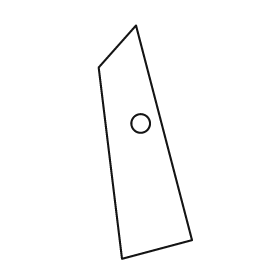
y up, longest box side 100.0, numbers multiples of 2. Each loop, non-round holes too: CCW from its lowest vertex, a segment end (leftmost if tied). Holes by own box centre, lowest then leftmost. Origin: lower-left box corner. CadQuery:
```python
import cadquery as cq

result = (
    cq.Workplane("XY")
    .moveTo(10.0, 0.0)
    .lineTo(40.0, 8.0)
    .lineTo(16.0, 100.0)
    .lineTo(0.0, 82.0)
    .close()
    .moveTo(18.0, 58.0)
    .circle(4.0)
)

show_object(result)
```